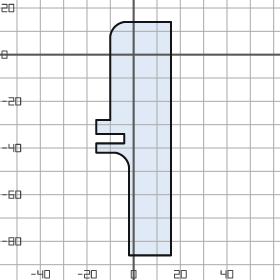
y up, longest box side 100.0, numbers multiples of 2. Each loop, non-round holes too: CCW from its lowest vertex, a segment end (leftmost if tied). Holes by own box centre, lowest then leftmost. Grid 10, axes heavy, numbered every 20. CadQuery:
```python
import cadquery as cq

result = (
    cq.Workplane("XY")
    .moveTo(-2.0, -86.0)
    .lineTo(16.0, -86.0)
    .lineTo(16.0, 14.0)
    .lineTo(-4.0, 14.0)
    .threePointArc((-8.0, 12.0), (-10.0, 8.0))
    .lineTo(-10.0, -28.0)
    .lineTo(-16.0, -28.0)
    .lineTo(-16.0, -34.0)
    .lineTo(-4.0, -34.0)
    .lineTo(-4.0, -38.0)
    .lineTo(-16.0, -38.0)
    .lineTo(-16.0, -42.0)
    .lineTo(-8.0, -42.0)
    .threePointArc((-4.0, -44.0), (-2.0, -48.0))
    .close()
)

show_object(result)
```